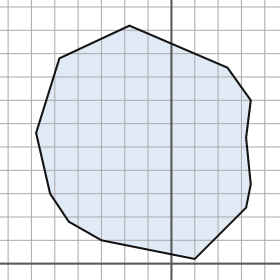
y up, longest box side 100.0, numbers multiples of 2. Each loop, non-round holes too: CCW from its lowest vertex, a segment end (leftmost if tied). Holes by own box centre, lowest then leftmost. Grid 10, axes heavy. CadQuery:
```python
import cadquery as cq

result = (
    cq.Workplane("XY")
    .moveTo(10.0, 2.0)
    .lineTo(32.0, 24.0)
    .lineTo(34.0, 34.0)
    .lineTo(32.0, 54.0)
    .lineTo(34.0, 70.0)
    .lineTo(24.0, 84.0)
    .lineTo(-18.0, 102.0)
    .lineTo(-48.0, 88.0)
    .lineTo(-58.0, 56.0)
    .lineTo(-52.0, 30.0)
    .lineTo(-44.0, 18.0)
    .lineTo(-30.0, 10.0)
    .close()
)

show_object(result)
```